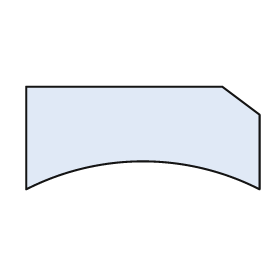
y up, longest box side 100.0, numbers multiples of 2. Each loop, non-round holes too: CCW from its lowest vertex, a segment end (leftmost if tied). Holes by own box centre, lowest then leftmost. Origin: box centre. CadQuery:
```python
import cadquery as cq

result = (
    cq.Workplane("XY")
    .moveTo(-50.0, -22.0)
    .threePointArc((0.0, -10.0), (50.0, -22.0))
    .lineTo(50.0, 10.0)
    .lineTo(34.0, 22.0)
    .lineTo(-50.0, 22.0)
    .close()
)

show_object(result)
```